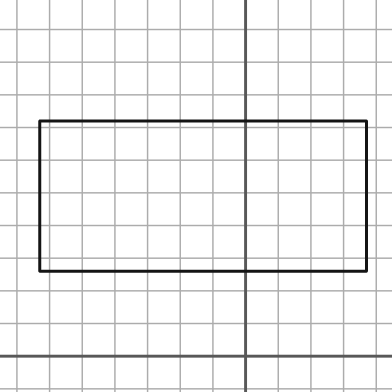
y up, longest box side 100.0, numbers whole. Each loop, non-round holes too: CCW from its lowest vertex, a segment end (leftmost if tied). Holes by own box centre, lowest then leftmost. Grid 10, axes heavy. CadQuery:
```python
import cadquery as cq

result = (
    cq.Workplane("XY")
    .moveTo(-63.0, 26.0)
    .lineTo(37.0, 26.0)
    .lineTo(37.0, 72.0)
    .lineTo(-63.0, 72.0)
    .close()
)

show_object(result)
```